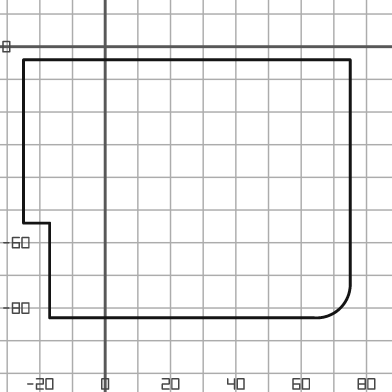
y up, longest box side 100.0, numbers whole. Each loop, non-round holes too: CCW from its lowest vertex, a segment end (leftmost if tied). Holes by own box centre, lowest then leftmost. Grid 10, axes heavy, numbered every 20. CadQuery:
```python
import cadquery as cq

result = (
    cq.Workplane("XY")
    .moveTo(-17.0, -83.0)
    .lineTo(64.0, -83.0)
    .threePointArc((72.0, -80.0), (75.0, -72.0))
    .lineTo(75.0, -4.0)
    .lineTo(-25.0, -4.0)
    .lineTo(-25.0, -54.0)
    .lineTo(-17.0, -54.0)
    .close()
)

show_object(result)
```